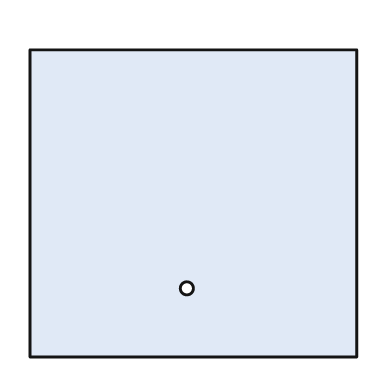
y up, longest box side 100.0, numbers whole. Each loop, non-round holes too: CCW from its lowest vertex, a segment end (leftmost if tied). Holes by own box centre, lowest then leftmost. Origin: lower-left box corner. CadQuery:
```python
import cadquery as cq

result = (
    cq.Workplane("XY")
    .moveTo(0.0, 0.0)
    .lineTo(100.0, 0.0)
    .lineTo(100.0, 94.0)
    .lineTo(0.0, 94.0)
    .close()
    .moveTo(48.0, 21.0)
    .circle(2.0)
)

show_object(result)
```